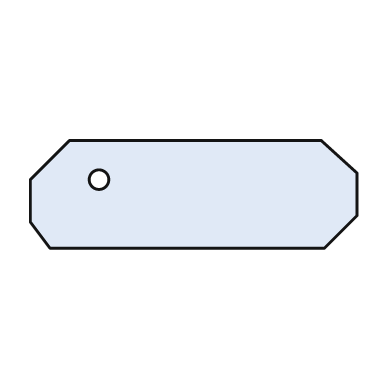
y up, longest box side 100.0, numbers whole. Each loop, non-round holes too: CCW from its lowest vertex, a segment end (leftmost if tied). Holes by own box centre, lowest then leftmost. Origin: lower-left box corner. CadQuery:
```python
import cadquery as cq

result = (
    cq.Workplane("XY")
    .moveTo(6.0, 0.0)
    .lineTo(90.0, 0.0)
    .lineTo(100.0, 10.0)
    .lineTo(100.0, 23.0)
    .lineTo(89.0, 33.0)
    .lineTo(12.0, 33.0)
    .lineTo(0.0, 21.0)
    .lineTo(0.0, 8.0)
    .close()
    .moveTo(21.0, 21.0)
    .circle(3.0)
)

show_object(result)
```